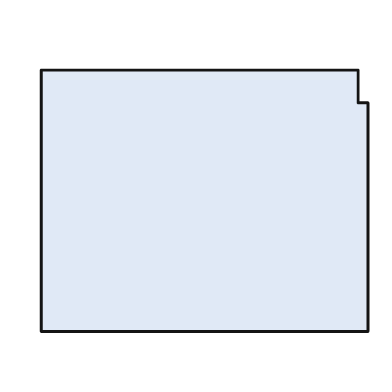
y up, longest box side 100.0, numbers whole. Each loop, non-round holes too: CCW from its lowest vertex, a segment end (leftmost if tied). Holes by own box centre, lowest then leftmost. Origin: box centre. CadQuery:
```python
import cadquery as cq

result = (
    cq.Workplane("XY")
    .moveTo(-50.0, -40.0)
    .lineTo(50.0, -40.0)
    .lineTo(50.0, 30.0)
    .lineTo(47.0, 30.0)
    .lineTo(47.0, 40.0)
    .lineTo(-50.0, 40.0)
    .close()
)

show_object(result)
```